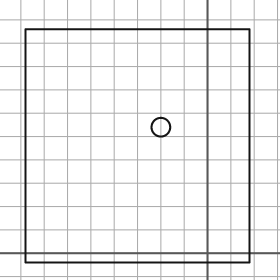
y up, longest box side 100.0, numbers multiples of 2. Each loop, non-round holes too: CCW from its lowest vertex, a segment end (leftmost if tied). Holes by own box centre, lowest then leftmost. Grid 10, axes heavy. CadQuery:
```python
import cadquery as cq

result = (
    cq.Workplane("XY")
    .moveTo(-78.0, -4.0)
    .lineTo(18.0, -4.0)
    .lineTo(18.0, 96.0)
    .lineTo(-78.0, 96.0)
    .close()
    .moveTo(-20.0, 54.0)
    .circle(4.0)
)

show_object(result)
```